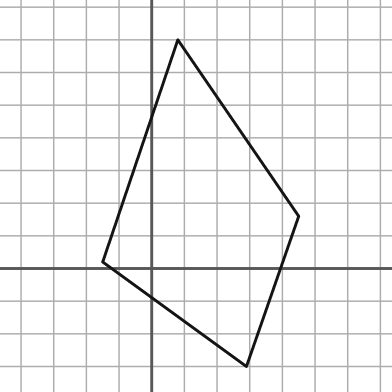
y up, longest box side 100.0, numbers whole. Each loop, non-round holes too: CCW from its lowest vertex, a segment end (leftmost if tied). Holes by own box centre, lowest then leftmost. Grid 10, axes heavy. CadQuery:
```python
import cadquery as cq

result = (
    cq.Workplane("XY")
    .moveTo(29.0, -30.0)
    .lineTo(45.0, 16.0)
    .lineTo(8.0, 70.0)
    .lineTo(-15.0, 2.0)
    .close()
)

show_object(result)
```